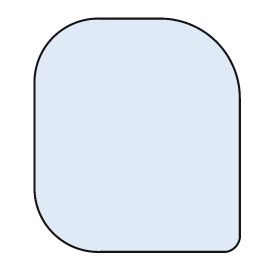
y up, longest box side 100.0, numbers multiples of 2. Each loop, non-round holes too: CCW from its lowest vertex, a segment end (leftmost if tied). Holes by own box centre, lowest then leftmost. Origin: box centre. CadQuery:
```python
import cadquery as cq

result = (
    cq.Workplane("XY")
    .moveTo(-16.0, -50.0)
    .lineTo(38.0, -50.0)
    .threePointArc((42.0, -48.0), (44.0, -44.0))
    .lineTo(44.0, 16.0)
    .threePointArc((34.0, 40.0), (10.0, 50.0))
    .lineTo(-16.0, 50.0)
    .threePointArc((-36.0, 42.0), (-44.0, 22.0))
    .lineTo(-44.0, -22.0)
    .threePointArc((-36.0, -42.0), (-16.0, -50.0))
    .close()
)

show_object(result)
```